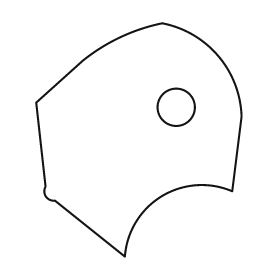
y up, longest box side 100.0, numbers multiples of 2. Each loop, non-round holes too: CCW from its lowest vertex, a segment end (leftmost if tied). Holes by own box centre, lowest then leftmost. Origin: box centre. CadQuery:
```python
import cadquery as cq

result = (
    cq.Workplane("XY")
    .moveTo(-6.0, -50.0)
    .threePointArc((10.0, -24.0), (40.0, -22.0))
    .lineTo(44.0, 10.0)
    .threePointArc((34.0, 36.0), (10.0, 50.0))
    .threePointArc((-8.0, 44.0), (-24.0, 34.0))
    .lineTo(-44.0, 16.0)
    .lineTo(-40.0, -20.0)
    .threePointArc((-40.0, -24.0), (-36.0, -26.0))
    .close()
    .moveTo(16.0, 14.0)
    .circle(8.0)
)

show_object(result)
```